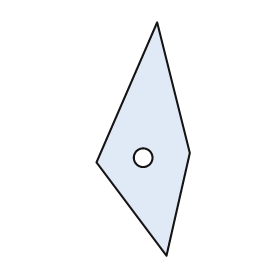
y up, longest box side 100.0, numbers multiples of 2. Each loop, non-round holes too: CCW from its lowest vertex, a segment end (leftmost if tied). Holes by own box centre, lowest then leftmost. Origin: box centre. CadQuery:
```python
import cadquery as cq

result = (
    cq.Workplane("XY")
    .moveTo(10.0, -50.0)
    .lineTo(20.0, -6.0)
    .lineTo(6.0, 50.0)
    .lineTo(-20.0, -10.0)
    .close()
    .moveTo(0.0, -8.0)
    .circle(4.0)
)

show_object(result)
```